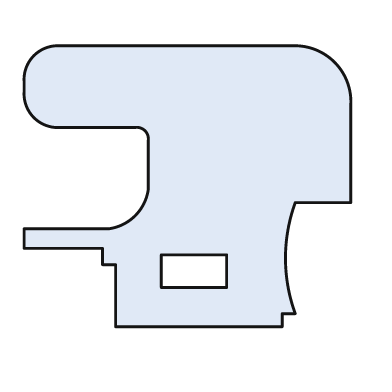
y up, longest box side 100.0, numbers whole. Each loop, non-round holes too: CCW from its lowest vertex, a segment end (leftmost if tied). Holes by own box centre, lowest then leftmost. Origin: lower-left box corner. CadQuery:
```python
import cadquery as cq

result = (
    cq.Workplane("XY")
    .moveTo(28.0, 0.0)
    .lineTo(79.0, 0.0)
    .lineTo(79.0, 4.0)
    .lineTo(83.0, 4.0)
    .threePointArc((80.0, 21.0), (83.0, 38.0))
    .lineTo(100.0, 38.0)
    .lineTo(100.0, 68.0)
    .threePointArc((95.0, 81.0), (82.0, 86.0))
    .lineTo(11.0, 86.0)
    .threePointArc((3.0, 83.0), (0.0, 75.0))
    .lineTo(0.0, 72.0)
    .threePointArc((3.0, 64.0), (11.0, 61.0))
    .lineTo(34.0, 61.0)
    .threePointArc((37.0, 60.0), (38.0, 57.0))
    .lineTo(38.0, 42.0)
    .threePointArc((34.0, 34.0), (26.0, 30.0))
    .lineTo(0.0, 30.0)
    .lineTo(0.0, 24.0)
    .lineTo(24.0, 24.0)
    .lineTo(24.0, 19.0)
    .lineTo(28.0, 19.0)
    .close()
    .moveTo(42.0, 12.0)
    .lineTo(62.0, 12.0)
    .lineTo(62.0, 22.0)
    .lineTo(42.0, 22.0)
    .close()
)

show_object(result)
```